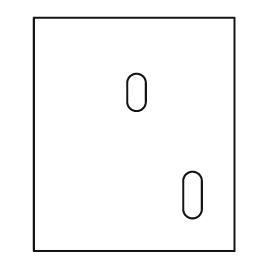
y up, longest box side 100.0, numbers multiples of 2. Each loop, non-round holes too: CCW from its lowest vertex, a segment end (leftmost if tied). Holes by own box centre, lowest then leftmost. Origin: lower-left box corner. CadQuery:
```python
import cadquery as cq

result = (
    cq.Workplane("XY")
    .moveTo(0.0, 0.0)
    .lineTo(86.0, 0.0)
    .lineTo(86.0, 100.0)
    .lineTo(0.0, 100.0)
    .close()
    .moveTo(64.0, 18.0)
    .threePointArc((68.0, 14.0), (72.0, 18.0))
    .lineTo(72.0, 30.0)
    .threePointArc((68.0, 34.0), (64.0, 30.0))
    .close()
    .moveTo(40.0, 64.0)
    .threePointArc((44.0, 60.0), (48.0, 64.0))
    .lineTo(48.0, 72.0)
    .threePointArc((44.0, 76.0), (40.0, 72.0))
    .close()
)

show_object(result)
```